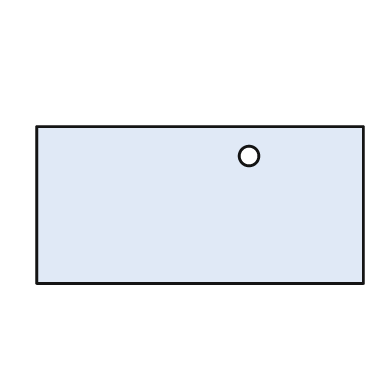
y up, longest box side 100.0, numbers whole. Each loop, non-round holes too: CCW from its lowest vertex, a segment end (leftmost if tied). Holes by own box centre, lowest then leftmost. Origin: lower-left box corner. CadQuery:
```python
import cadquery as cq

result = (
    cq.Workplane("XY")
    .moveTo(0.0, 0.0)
    .lineTo(100.0, 0.0)
    .lineTo(100.0, 48.0)
    .lineTo(0.0, 48.0)
    .close()
    .moveTo(65.0, 39.0)
    .circle(3.0)
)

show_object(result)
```